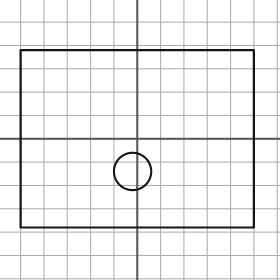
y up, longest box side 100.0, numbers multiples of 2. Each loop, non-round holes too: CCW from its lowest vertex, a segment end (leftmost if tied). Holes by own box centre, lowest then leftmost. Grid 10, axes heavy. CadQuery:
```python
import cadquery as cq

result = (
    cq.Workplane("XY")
    .moveTo(-50.0, -38.0)
    .lineTo(50.0, -38.0)
    .lineTo(50.0, 38.0)
    .lineTo(-50.0, 38.0)
    .close()
    .moveTo(-2.0, -14.0)
    .circle(8.0)
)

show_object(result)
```